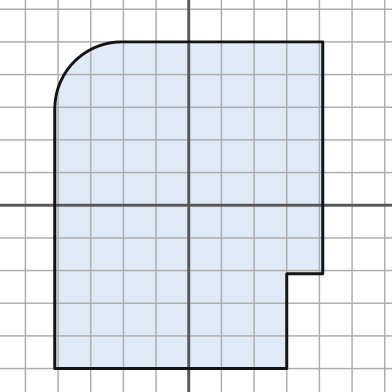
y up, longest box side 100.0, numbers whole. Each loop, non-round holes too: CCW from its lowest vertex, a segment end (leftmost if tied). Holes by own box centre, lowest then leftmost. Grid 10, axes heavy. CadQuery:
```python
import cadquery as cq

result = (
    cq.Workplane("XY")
    .moveTo(-41.0, -50.0)
    .lineTo(30.0, -50.0)
    .lineTo(30.0, -21.0)
    .lineTo(41.0, -21.0)
    .lineTo(41.0, 50.0)
    .lineTo(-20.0, 50.0)
    .threePointArc((-35.0, 44.0), (-41.0, 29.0))
    .close()
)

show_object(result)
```